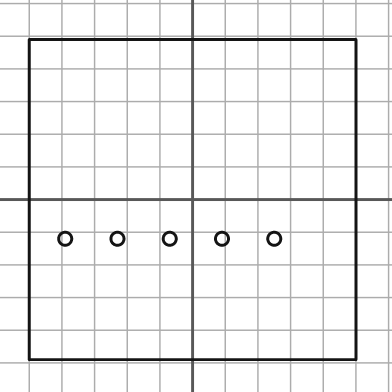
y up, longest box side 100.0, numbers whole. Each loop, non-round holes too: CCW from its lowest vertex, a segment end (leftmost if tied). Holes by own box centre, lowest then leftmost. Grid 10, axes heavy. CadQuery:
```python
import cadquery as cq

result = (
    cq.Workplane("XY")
    .moveTo(-50.0, -49.0)
    .lineTo(50.0, -49.0)
    .lineTo(50.0, 49.0)
    .lineTo(-50.0, 49.0)
    .close()
    .moveTo(-39.0, -12.0)
    .circle(2.0)
    .moveTo(-23.0, -12.0)
    .circle(2.0)
    .moveTo(-7.0, -12.0)
    .circle(2.0)
    .moveTo(9.0, -12.0)
    .circle(2.0)
    .moveTo(25.0, -12.0)
    .circle(2.0)
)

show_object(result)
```